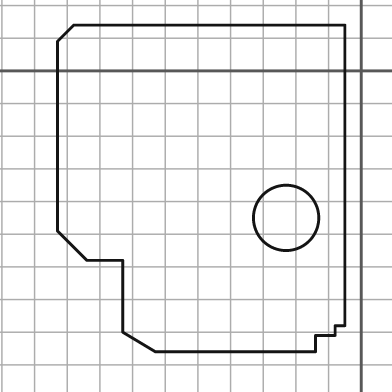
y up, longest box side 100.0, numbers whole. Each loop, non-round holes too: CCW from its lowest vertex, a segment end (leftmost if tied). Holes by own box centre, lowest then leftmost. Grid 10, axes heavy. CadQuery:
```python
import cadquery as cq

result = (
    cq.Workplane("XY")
    .moveTo(-63.0, -86.0)
    .lineTo(-14.0, -86.0)
    .lineTo(-14.0, -81.0)
    .lineTo(-8.0, -81.0)
    .lineTo(-8.0, -78.0)
    .lineTo(-5.0, -78.0)
    .lineTo(-5.0, 14.0)
    .lineTo(-88.0, 14.0)
    .lineTo(-93.0, 9.0)
    .lineTo(-93.0, -49.0)
    .lineTo(-84.0, -58.0)
    .lineTo(-73.0, -58.0)
    .lineTo(-73.0, -80.0)
    .close()
    .moveTo(-23.0, -45.0)
    .circle(10.0)
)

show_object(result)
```